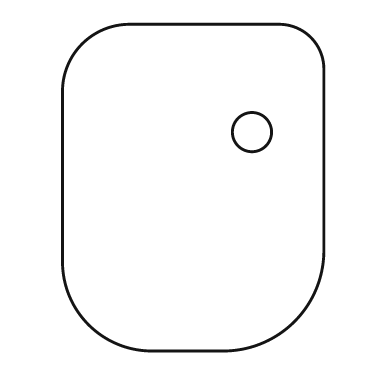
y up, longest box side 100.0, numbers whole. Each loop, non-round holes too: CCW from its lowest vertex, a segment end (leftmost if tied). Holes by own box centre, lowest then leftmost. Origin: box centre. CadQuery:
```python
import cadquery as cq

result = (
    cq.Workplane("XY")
    .moveTo(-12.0, -50.0)
    .lineTo(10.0, -50.0)
    .threePointArc((31.0, -41.0), (40.0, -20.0))
    .lineTo(40.0, 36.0)
    .threePointArc((36.0, 46.0), (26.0, 50.0))
    .lineTo(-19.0, 50.0)
    .threePointArc((-34.0, 44.0), (-40.0, 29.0))
    .lineTo(-40.0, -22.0)
    .threePointArc((-32.0, -42.0), (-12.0, -50.0))
    .close()
    .moveTo(18.0, 17.0)
    .circle(6.0)
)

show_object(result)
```